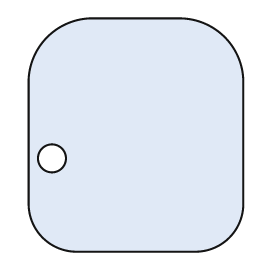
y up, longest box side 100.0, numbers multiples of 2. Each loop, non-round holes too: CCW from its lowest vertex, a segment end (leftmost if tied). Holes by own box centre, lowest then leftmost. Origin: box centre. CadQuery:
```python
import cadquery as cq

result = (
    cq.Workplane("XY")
    .moveTo(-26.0, -50.0)
    .lineTo(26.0, -50.0)
    .threePointArc((40.0, -44.0), (46.0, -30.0))
    .lineTo(46.0, 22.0)
    .threePointArc((38.0, 42.0), (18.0, 50.0))
    .lineTo(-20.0, 50.0)
    .threePointArc((-38.0, 42.0), (-46.0, 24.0))
    .lineTo(-46.0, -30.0)
    .threePointArc((-40.0, -44.0), (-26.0, -50.0))
    .close()
    .moveTo(-36.0, -10.0)
    .circle(6.0)
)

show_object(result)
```